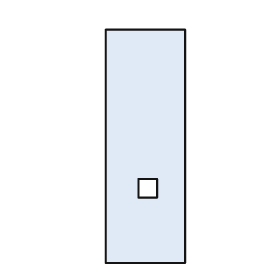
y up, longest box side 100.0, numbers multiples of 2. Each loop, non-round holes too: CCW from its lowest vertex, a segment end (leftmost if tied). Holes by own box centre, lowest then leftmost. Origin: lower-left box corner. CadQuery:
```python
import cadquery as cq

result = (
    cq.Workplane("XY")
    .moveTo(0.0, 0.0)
    .lineTo(34.0, 0.0)
    .lineTo(34.0, 100.0)
    .lineTo(0.0, 100.0)
    .close()
    .moveTo(14.0, 28.0)
    .lineTo(22.0, 28.0)
    .lineTo(22.0, 36.0)
    .lineTo(14.0, 36.0)
    .close()
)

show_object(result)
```